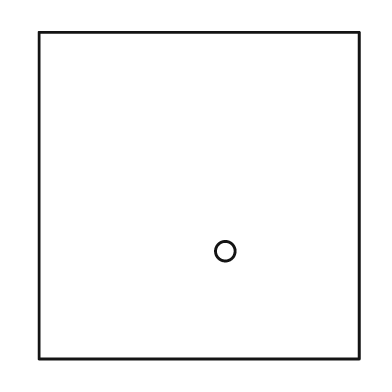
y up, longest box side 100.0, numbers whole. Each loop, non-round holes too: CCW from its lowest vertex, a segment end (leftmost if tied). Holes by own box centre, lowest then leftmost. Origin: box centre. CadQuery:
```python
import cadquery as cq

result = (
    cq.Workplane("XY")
    .moveTo(-49.0, -50.0)
    .lineTo(49.0, -50.0)
    .lineTo(49.0, 50.0)
    .lineTo(-49.0, 50.0)
    .close()
    .moveTo(8.0, -17.0)
    .circle(3.0)
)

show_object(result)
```